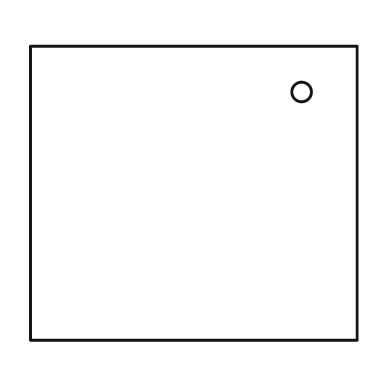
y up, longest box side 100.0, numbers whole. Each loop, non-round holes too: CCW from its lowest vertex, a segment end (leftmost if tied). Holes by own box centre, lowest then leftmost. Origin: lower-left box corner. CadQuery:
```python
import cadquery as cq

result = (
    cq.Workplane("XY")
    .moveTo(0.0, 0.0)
    .lineTo(100.0, 0.0)
    .lineTo(100.0, 90.0)
    .lineTo(0.0, 90.0)
    .close()
    .moveTo(83.0, 76.0)
    .circle(3.0)
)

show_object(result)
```